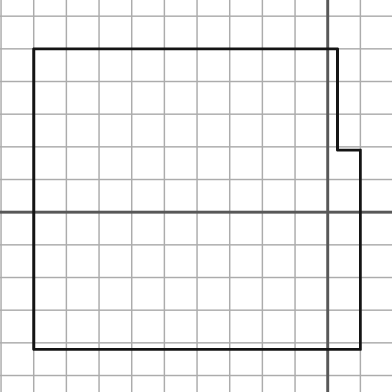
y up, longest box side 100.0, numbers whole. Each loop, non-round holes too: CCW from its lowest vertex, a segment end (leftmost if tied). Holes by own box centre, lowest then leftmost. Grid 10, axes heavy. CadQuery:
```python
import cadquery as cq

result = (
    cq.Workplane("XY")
    .moveTo(-90.0, -42.0)
    .lineTo(10.0, -42.0)
    .lineTo(10.0, 19.0)
    .lineTo(3.0, 19.0)
    .lineTo(3.0, 50.0)
    .lineTo(-90.0, 50.0)
    .close()
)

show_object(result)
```